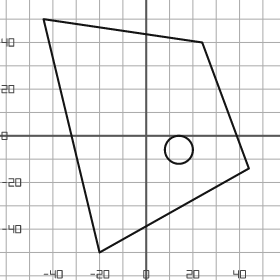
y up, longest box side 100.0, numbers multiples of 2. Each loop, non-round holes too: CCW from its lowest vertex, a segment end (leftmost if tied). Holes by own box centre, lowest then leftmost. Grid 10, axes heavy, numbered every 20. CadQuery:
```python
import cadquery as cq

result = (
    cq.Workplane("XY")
    .moveTo(-20.0, -50.0)
    .lineTo(44.0, -14.0)
    .lineTo(24.0, 40.0)
    .lineTo(-44.0, 50.0)
    .close()
    .moveTo(14.0, -6.0)
    .circle(6.0)
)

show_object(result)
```